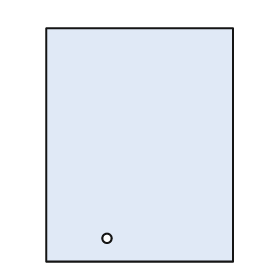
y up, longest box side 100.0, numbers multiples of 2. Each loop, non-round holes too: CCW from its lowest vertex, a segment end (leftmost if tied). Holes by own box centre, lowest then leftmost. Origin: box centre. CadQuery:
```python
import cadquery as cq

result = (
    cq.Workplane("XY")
    .moveTo(-40.0, -50.0)
    .lineTo(40.0, -50.0)
    .lineTo(40.0, 50.0)
    .lineTo(-40.0, 50.0)
    .close()
    .moveTo(-14.0, -40.0)
    .circle(2.0)
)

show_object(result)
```